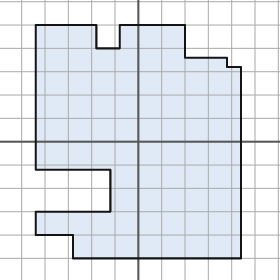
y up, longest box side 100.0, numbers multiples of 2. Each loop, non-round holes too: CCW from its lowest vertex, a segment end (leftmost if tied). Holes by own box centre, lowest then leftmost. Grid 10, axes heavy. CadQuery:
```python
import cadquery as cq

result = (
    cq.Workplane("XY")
    .moveTo(-28.0, -50.0)
    .lineTo(44.0, -50.0)
    .lineTo(44.0, 32.0)
    .lineTo(38.0, 32.0)
    .lineTo(38.0, 36.0)
    .lineTo(20.0, 36.0)
    .lineTo(20.0, 50.0)
    .lineTo(-8.0, 50.0)
    .lineTo(-8.0, 40.0)
    .lineTo(-18.0, 40.0)
    .lineTo(-18.0, 50.0)
    .lineTo(-44.0, 50.0)
    .lineTo(-44.0, -12.0)
    .lineTo(-12.0, -12.0)
    .lineTo(-12.0, -30.0)
    .lineTo(-44.0, -30.0)
    .lineTo(-44.0, -40.0)
    .lineTo(-28.0, -40.0)
    .close()
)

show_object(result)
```